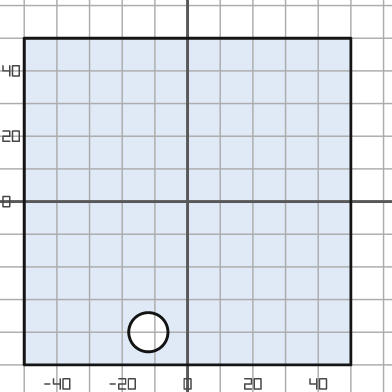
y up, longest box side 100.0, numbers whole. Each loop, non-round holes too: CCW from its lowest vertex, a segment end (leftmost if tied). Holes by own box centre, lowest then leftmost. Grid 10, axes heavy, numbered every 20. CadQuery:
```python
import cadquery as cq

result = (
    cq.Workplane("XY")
    .moveTo(-50.0, -50.0)
    .lineTo(50.0, -50.0)
    .lineTo(50.0, 50.0)
    .lineTo(-50.0, 50.0)
    .close()
    .moveTo(-12.0, -40.0)
    .circle(6.0)
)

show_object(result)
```